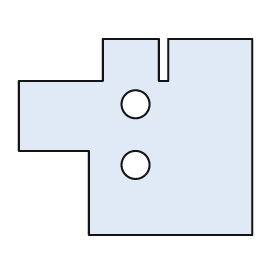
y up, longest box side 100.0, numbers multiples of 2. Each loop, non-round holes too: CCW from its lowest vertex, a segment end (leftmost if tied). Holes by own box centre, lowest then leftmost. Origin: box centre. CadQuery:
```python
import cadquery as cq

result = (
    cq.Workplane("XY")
    .moveTo(-20.0, -42.0)
    .lineTo(50.0, -42.0)
    .lineTo(50.0, 42.0)
    .lineTo(14.0, 42.0)
    .lineTo(14.0, 24.0)
    .lineTo(10.0, 24.0)
    .lineTo(10.0, 42.0)
    .lineTo(-14.0, 42.0)
    .lineTo(-14.0, 24.0)
    .lineTo(-50.0, 24.0)
    .lineTo(-50.0, -6.0)
    .lineTo(-20.0, -6.0)
    .close()
    .moveTo(0.0, -12.0)
    .circle(6.0)
    .moveTo(0.0, 14.0)
    .circle(6.0)
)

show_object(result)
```